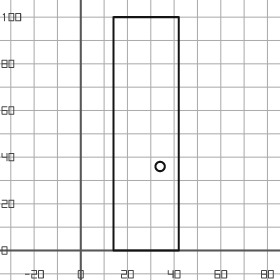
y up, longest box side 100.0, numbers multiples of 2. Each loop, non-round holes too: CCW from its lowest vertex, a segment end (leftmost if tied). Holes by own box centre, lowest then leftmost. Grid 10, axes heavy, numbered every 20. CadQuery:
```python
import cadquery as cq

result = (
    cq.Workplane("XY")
    .moveTo(14.0, 0.0)
    .lineTo(42.0, 0.0)
    .lineTo(42.0, 100.0)
    .lineTo(14.0, 100.0)
    .close()
    .moveTo(34.0, 36.0)
    .circle(2.0)
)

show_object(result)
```